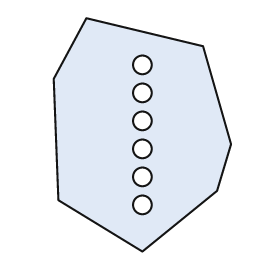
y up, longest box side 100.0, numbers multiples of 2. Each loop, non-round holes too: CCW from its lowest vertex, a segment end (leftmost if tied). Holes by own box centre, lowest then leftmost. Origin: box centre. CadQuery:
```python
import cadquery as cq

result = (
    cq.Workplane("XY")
    .moveTo(0.0, -50.0)
    .lineTo(32.0, -24.0)
    .lineTo(38.0, -4.0)
    .lineTo(26.0, 38.0)
    .lineTo(-24.0, 50.0)
    .lineTo(-38.0, 24.0)
    .lineTo(-36.0, -28.0)
    .close()
    .moveTo(0.0, -30.0)
    .circle(4.0)
    .moveTo(0.0, -18.0)
    .circle(4.0)
    .moveTo(0.0, -6.0)
    .circle(4.0)
    .moveTo(0.0, 6.0)
    .circle(4.0)
    .moveTo(0.0, 18.0)
    .circle(4.0)
    .moveTo(0.0, 30.0)
    .circle(4.0)
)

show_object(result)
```